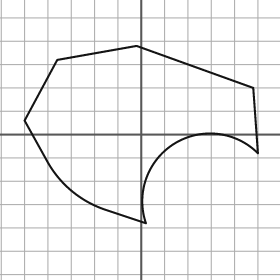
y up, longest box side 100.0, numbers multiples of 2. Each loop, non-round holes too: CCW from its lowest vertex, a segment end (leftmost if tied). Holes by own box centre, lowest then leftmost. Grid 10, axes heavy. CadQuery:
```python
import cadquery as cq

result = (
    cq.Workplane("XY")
    .moveTo(2.0, -38.0)
    .threePointArc((14.0, -4.0), (50.0, -8.0))
    .lineTo(48.0, 20.0)
    .lineTo(-2.0, 38.0)
    .lineTo(-36.0, 32.0)
    .lineTo(-50.0, 6.0)
    .lineTo(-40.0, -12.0)
    .threePointArc((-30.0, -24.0), (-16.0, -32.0))
    .close()
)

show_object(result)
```